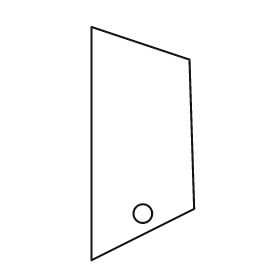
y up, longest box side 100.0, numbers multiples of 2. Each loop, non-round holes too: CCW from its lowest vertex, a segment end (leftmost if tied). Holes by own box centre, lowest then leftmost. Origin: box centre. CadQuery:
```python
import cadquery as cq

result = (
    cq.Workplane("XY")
    .moveTo(-22.0, -50.0)
    .lineTo(22.0, -28.0)
    .lineTo(20.0, 36.0)
    .lineTo(-22.0, 50.0)
    .close()
    .moveTo(0.0, -30.0)
    .circle(4.0)
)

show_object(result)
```